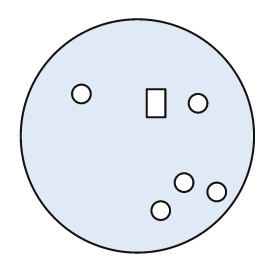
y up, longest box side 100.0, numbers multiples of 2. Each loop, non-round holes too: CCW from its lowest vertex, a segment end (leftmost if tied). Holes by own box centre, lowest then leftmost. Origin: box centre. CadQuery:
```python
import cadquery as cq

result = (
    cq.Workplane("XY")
    .moveTo(0.0, 0.0)
    .circle(50.0)
    .moveTo(10.0, -32.0)
    .circle(4.0)
    .moveTo(34.0, -24.0)
    .circle(4.0)
    .moveTo(20.0, -20.0)
    .circle(4.0)
    .moveTo(4.0, 8.0)
    .lineTo(12.0, 8.0)
    .lineTo(12.0, 20.0)
    .lineTo(4.0, 20.0)
    .close()
    .moveTo(26.0, 14.0)
    .circle(4.0)
    .moveTo(-24.0, 18.0)
    .circle(4.0)
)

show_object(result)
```